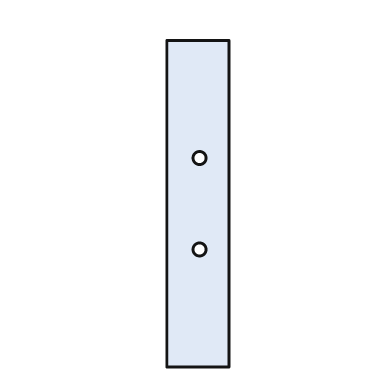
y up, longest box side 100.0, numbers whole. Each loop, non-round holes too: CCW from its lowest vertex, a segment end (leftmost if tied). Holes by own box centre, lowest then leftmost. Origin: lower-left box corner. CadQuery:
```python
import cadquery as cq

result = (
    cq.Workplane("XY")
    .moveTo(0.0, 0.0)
    .lineTo(19.0, 0.0)
    .lineTo(19.0, 100.0)
    .lineTo(0.0, 100.0)
    .close()
    .moveTo(10.0, 36.0)
    .circle(2.0)
    .moveTo(10.0, 64.0)
    .circle(2.0)
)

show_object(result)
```